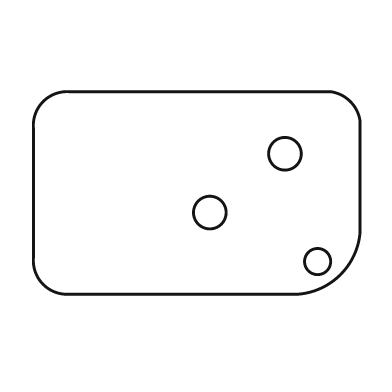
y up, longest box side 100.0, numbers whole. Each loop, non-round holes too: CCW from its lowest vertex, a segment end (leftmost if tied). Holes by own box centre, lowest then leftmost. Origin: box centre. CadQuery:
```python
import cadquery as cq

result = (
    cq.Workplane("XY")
    .moveTo(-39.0, -31.0)
    .lineTo(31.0, -31.0)
    .threePointArc((44.0, -25.0), (50.0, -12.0))
    .lineTo(50.0, 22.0)
    .threePointArc((47.0, 28.0), (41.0, 31.0))
    .lineTo(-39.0, 31.0)
    .threePointArc((-47.0, 28.0), (-50.0, 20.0))
    .lineTo(-50.0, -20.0)
    .threePointArc((-47.0, -28.0), (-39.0, -31.0))
    .close()
    .moveTo(37.0, -21.0)
    .circle(4.0)
    .moveTo(4.0, -6.0)
    .circle(5.0)
    .moveTo(27.0, 12.0)
    .circle(5.0)
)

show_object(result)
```